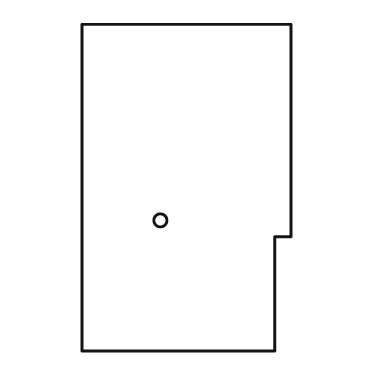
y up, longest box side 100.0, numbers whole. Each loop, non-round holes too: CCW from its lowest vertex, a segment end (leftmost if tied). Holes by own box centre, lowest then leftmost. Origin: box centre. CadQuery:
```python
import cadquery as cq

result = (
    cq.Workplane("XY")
    .moveTo(-32.0, -50.0)
    .lineTo(27.0, -50.0)
    .lineTo(27.0, -15.0)
    .lineTo(32.0, -15.0)
    .lineTo(32.0, 50.0)
    .lineTo(-32.0, 50.0)
    .close()
    .moveTo(-8.0, -10.0)
    .circle(2.0)
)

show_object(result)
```